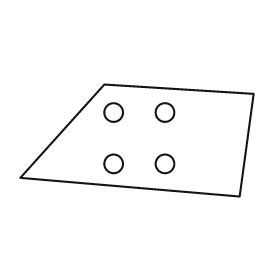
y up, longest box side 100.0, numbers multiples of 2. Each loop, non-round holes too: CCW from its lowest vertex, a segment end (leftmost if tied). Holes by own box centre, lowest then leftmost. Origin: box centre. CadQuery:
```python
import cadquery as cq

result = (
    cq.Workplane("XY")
    .moveTo(44.0, -24.0)
    .lineTo(50.0, 20.0)
    .lineTo(-14.0, 24.0)
    .lineTo(-50.0, -16.0)
    .close()
    .moveTo(-10.0, -10.0)
    .circle(4.0)
    .moveTo(12.0, -10.0)
    .circle(4.0)
    .moveTo(-10.0, 12.0)
    .circle(4.0)
    .moveTo(12.0, 12.0)
    .circle(4.0)
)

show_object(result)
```